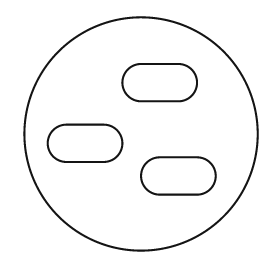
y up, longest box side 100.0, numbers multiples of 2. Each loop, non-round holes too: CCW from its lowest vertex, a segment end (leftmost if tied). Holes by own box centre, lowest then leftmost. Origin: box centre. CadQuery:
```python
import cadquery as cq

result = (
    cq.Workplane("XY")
    .moveTo(0.0, 0.0)
    .circle(50.0)
    .moveTo(8.0, -26.0)
    .lineTo(24.0, -26.0)
    .threePointArc((32.0, -18.0), (24.0, -10.0))
    .lineTo(8.0, -10.0)
    .threePointArc((0.0, -18.0), (8.0, -26.0))
    .close()
    .moveTo(-32.0, -12.0)
    .lineTo(-16.0, -12.0)
    .threePointArc((-8.0, -4.0), (-16.0, 4.0))
    .lineTo(-32.0, 4.0)
    .threePointArc((-40.0, -4.0), (-32.0, -12.0))
    .close()
    .moveTo(0.0, 14.0)
    .lineTo(16.0, 14.0)
    .threePointArc((24.0, 22.0), (16.0, 30.0))
    .lineTo(0.0, 30.0)
    .threePointArc((-8.0, 22.0), (0.0, 14.0))
    .close()
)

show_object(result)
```